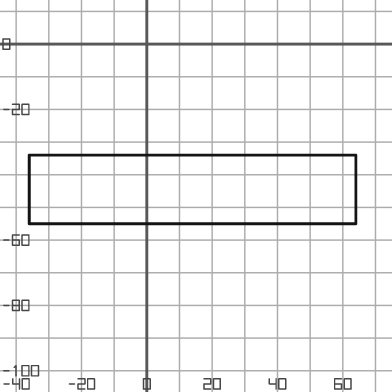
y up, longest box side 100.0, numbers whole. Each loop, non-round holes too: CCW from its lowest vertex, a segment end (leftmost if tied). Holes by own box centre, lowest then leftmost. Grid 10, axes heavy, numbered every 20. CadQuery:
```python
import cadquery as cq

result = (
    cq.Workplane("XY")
    .moveTo(-36.0, -55.0)
    .lineTo(64.0, -55.0)
    .lineTo(64.0, -34.0)
    .lineTo(-36.0, -34.0)
    .close()
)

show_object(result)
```